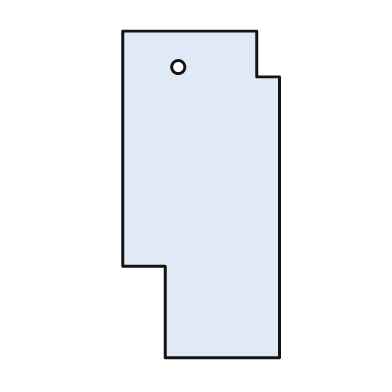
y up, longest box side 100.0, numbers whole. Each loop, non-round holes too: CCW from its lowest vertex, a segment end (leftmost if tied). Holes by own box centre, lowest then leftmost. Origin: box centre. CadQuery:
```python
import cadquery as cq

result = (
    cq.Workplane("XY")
    .moveTo(-11.0, -50.0)
    .lineTo(24.0, -50.0)
    .lineTo(24.0, 36.0)
    .lineTo(17.0, 36.0)
    .lineTo(17.0, 50.0)
    .lineTo(-24.0, 50.0)
    .lineTo(-24.0, -22.0)
    .lineTo(-11.0, -22.0)
    .close()
    .moveTo(-7.0, 39.0)
    .circle(2.0)
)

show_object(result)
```